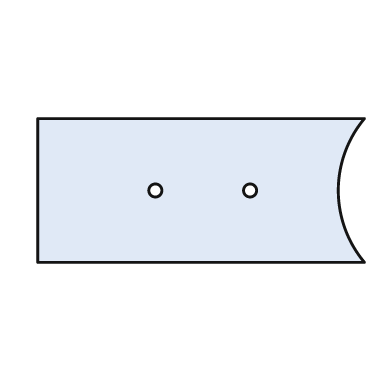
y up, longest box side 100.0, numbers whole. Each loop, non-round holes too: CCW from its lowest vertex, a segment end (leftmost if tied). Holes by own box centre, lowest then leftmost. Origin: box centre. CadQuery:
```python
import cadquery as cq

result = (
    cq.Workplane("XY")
    .moveTo(-50.0, -22.0)
    .lineTo(50.0, -22.0)
    .threePointArc((42.0, 0.0), (50.0, 22.0))
    .lineTo(-50.0, 22.0)
    .close()
    .moveTo(-14.0, 0.0)
    .circle(2.0)
    .moveTo(15.0, 0.0)
    .circle(2.0)
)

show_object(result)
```